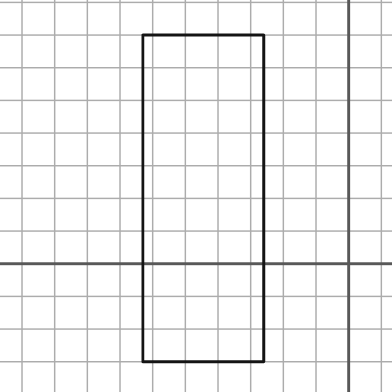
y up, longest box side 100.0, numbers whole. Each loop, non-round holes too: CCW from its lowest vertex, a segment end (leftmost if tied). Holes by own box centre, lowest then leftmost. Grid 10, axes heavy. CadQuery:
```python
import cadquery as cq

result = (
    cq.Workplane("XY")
    .moveTo(-63.0, -30.0)
    .lineTo(-26.0, -30.0)
    .lineTo(-26.0, 70.0)
    .lineTo(-63.0, 70.0)
    .close()
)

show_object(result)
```